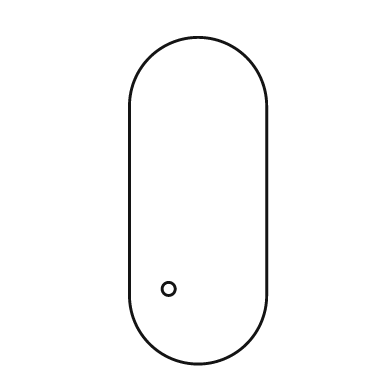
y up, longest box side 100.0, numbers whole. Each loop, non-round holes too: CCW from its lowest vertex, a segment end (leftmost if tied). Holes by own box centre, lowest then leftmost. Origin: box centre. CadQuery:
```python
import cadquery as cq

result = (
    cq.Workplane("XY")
    .moveTo(-21.0, -29.0)
    .threePointArc((0.0, -50.0), (21.0, -29.0))
    .lineTo(21.0, 29.0)
    .threePointArc((0.0, 50.0), (-21.0, 29.0))
    .close()
    .moveTo(-9.0, -27.0)
    .circle(2.0)
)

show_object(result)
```